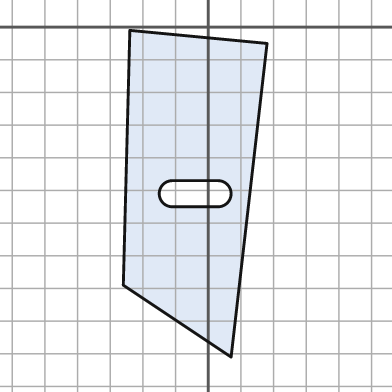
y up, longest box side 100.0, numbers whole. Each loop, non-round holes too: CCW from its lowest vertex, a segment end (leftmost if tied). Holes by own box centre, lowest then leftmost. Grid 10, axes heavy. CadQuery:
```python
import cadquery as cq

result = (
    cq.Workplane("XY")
    .moveTo(7.0, -101.0)
    .lineTo(18.0, -5.0)
    .lineTo(-24.0, -1.0)
    .lineTo(-26.0, -79.0)
    .close()
    .moveTo(-11.0, -55.0)
    .lineTo(3.0, -55.0)
    .threePointArc((7.0, -51.0), (3.0, -47.0))
    .lineTo(-11.0, -47.0)
    .threePointArc((-15.0, -51.0), (-11.0, -55.0))
    .close()
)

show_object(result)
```